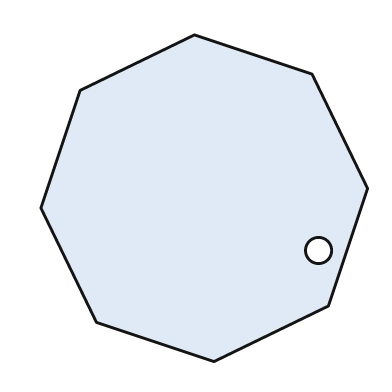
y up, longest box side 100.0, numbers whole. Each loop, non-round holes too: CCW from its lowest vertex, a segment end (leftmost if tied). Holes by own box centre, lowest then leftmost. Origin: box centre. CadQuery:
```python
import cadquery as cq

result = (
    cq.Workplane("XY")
    .moveTo(3.0, -50.0)
    .lineTo(38.0, -33.0)
    .lineTo(50.0, 3.0)
    .lineTo(33.0, 38.0)
    .lineTo(-3.0, 50.0)
    .lineTo(-38.0, 33.0)
    .lineTo(-50.0, -3.0)
    .lineTo(-33.0, -38.0)
    .close()
    .moveTo(35.0, -16.0)
    .circle(4.0)
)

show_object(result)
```